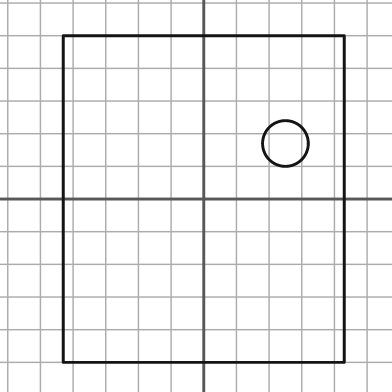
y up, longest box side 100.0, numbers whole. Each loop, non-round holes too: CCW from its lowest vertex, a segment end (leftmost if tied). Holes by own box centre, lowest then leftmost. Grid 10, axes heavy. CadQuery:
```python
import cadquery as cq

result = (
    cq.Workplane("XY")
    .moveTo(-43.0, -50.0)
    .lineTo(43.0, -50.0)
    .lineTo(43.0, 50.0)
    .lineTo(-43.0, 50.0)
    .close()
    .moveTo(25.0, 17.0)
    .circle(7.0)
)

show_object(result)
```